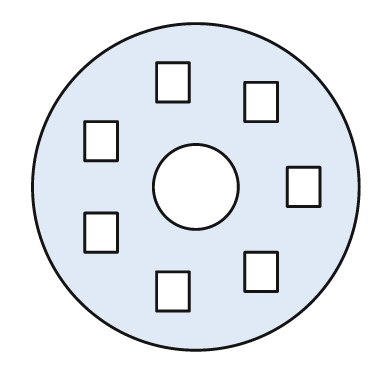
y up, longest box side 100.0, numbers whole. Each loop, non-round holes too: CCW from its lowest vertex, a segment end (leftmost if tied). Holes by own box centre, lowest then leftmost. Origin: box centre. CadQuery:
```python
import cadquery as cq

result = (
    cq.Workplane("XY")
    .moveTo(0.0, 0.0)
    .circle(50.0)
    .moveTo(-12.0, -38.0)
    .lineTo(-2.0, -38.0)
    .lineTo(-2.0, -26.0)
    .lineTo(-12.0, -26.0)
    .close()
    .moveTo(15.0, -32.0)
    .lineTo(25.0, -32.0)
    .lineTo(25.0, -20.0)
    .lineTo(15.0, -20.0)
    .close()
    .moveTo(-34.0, -20.0)
    .lineTo(-24.0, -20.0)
    .lineTo(-24.0, -8.0)
    .lineTo(-34.0, -8.0)
    .close()
    .moveTo(0.0, 0.0)
    .circle(13.0)
    .moveTo(28.0, -6.0)
    .lineTo(38.0, -6.0)
    .lineTo(38.0, 6.0)
    .lineTo(28.0, 6.0)
    .close()
    .moveTo(-34.0, 8.0)
    .lineTo(-24.0, 8.0)
    .lineTo(-24.0, 20.0)
    .lineTo(-34.0, 20.0)
    .close()
    .moveTo(15.0, 20.0)
    .lineTo(25.0, 20.0)
    .lineTo(25.0, 32.0)
    .lineTo(15.0, 32.0)
    .close()
    .moveTo(-12.0, 26.0)
    .lineTo(-2.0, 26.0)
    .lineTo(-2.0, 38.0)
    .lineTo(-12.0, 38.0)
    .close()
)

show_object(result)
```